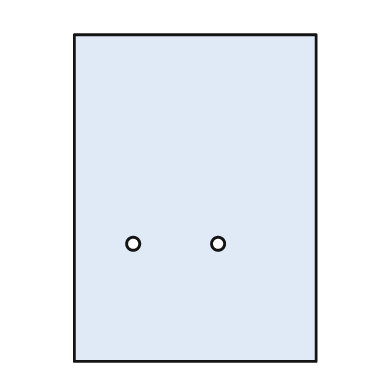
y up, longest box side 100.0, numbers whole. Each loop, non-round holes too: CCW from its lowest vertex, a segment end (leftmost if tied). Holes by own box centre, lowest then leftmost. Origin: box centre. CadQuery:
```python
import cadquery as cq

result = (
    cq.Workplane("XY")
    .moveTo(-37.0, -50.0)
    .lineTo(37.0, -50.0)
    .lineTo(37.0, 50.0)
    .lineTo(-37.0, 50.0)
    .close()
    .moveTo(-19.0, -14.0)
    .circle(2.0)
    .moveTo(7.0, -14.0)
    .circle(2.0)
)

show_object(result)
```